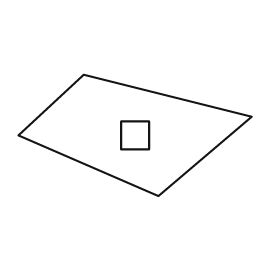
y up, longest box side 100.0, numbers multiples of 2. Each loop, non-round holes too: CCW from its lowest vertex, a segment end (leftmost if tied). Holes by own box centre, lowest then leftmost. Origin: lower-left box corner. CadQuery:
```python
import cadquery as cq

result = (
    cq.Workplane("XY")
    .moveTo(60.0, 0.0)
    .lineTo(100.0, 34.0)
    .lineTo(28.0, 52.0)
    .lineTo(0.0, 26.0)
    .close()
    .moveTo(44.0, 20.0)
    .lineTo(56.0, 20.0)
    .lineTo(56.0, 32.0)
    .lineTo(44.0, 32.0)
    .close()
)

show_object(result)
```